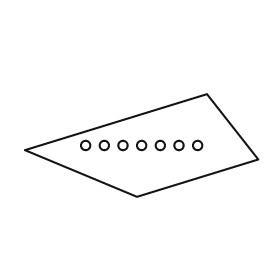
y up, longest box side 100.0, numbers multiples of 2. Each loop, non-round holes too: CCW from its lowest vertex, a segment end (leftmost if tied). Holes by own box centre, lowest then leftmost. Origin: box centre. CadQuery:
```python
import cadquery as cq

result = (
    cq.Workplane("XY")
    .moveTo(-2.0, -22.0)
    .lineTo(50.0, -6.0)
    .lineTo(28.0, 22.0)
    .lineTo(-50.0, -2.0)
    .close()
    .moveTo(-24.0, 0.0)
    .circle(2.0)
    .moveTo(-16.0, 0.0)
    .circle(2.0)
    .moveTo(-8.0, 0.0)
    .circle(2.0)
    .moveTo(0.0, 0.0)
    .circle(2.0)
    .moveTo(8.0, 0.0)
    .circle(2.0)
    .moveTo(16.0, 0.0)
    .circle(2.0)
    .moveTo(24.0, 0.0)
    .circle(2.0)
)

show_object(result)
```